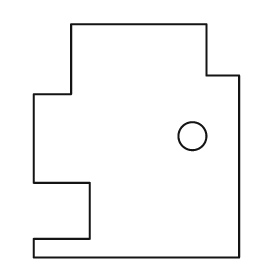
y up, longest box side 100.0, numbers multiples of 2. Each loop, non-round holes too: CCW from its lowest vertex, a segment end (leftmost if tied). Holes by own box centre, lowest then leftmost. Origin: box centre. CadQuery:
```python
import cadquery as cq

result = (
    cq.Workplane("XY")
    .moveTo(-44.0, -50.0)
    .lineTo(44.0, -50.0)
    .lineTo(44.0, 28.0)
    .lineTo(30.0, 28.0)
    .lineTo(30.0, 50.0)
    .lineTo(-28.0, 50.0)
    .lineTo(-28.0, 20.0)
    .lineTo(-44.0, 20.0)
    .lineTo(-44.0, -18.0)
    .lineTo(-20.0, -18.0)
    .lineTo(-20.0, -42.0)
    .lineTo(-44.0, -42.0)
    .close()
    .moveTo(24.0, 2.0)
    .circle(6.0)
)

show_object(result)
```